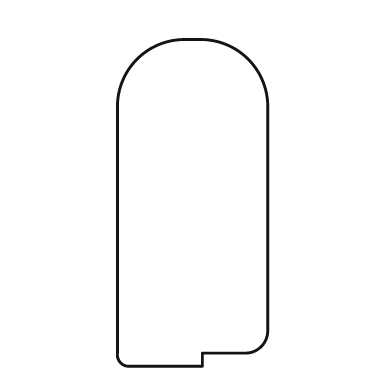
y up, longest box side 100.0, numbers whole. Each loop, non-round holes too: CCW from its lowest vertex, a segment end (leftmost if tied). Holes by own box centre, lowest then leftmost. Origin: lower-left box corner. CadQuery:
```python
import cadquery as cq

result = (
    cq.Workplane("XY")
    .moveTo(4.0, 0.0)
    .lineTo(26.0, 0.0)
    .lineTo(26.0, 4.0)
    .lineTo(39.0, 4.0)
    .threePointArc((44.0, 6.0), (46.0, 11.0))
    .lineTo(46.0, 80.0)
    .threePointArc((40.0, 94.0), (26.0, 100.0))
    .lineTo(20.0, 100.0)
    .threePointArc((6.0, 94.0), (0.0, 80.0))
    .lineTo(0.0, 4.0)
    .threePointArc((1.0, 1.0), (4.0, 0.0))
    .close()
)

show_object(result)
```